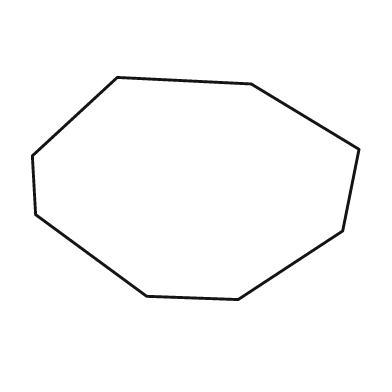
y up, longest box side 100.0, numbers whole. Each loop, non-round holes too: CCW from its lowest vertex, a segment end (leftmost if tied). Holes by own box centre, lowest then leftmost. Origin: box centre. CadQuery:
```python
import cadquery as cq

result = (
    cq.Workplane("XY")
    .moveTo(13.0, -34.0)
    .lineTo(45.0, -13.0)
    .lineTo(50.0, 12.0)
    .lineTo(17.0, 32.0)
    .lineTo(-24.0, 34.0)
    .lineTo(-50.0, 10.0)
    .lineTo(-49.0, -8.0)
    .lineTo(-15.0, -33.0)
    .close()
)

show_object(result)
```